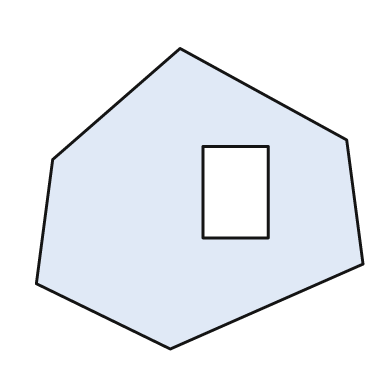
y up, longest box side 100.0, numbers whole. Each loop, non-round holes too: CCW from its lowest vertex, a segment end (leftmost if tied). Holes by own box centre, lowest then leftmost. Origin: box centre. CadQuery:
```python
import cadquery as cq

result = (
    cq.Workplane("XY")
    .moveTo(-9.0, -46.0)
    .lineTo(50.0, -20.0)
    .lineTo(45.0, 18.0)
    .lineTo(-6.0, 46.0)
    .lineTo(-45.0, 12.0)
    .lineTo(-50.0, -26.0)
    .close()
    .moveTo(1.0, -12.0)
    .lineTo(21.0, -12.0)
    .lineTo(21.0, 16.0)
    .lineTo(1.0, 16.0)
    .close()
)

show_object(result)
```